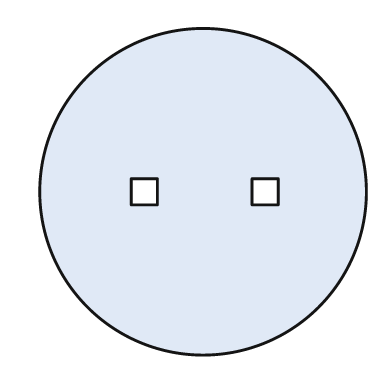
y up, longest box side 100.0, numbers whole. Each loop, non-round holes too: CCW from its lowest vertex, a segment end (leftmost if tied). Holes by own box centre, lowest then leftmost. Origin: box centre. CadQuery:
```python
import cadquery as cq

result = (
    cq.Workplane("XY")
    .moveTo(0.0, 0.0)
    .circle(50.0)
    .moveTo(-22.0, -4.0)
    .lineTo(-14.0, -4.0)
    .lineTo(-14.0, 4.0)
    .lineTo(-22.0, 4.0)
    .close()
    .moveTo(15.0, -4.0)
    .lineTo(23.0, -4.0)
    .lineTo(23.0, 4.0)
    .lineTo(15.0, 4.0)
    .close()
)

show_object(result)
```